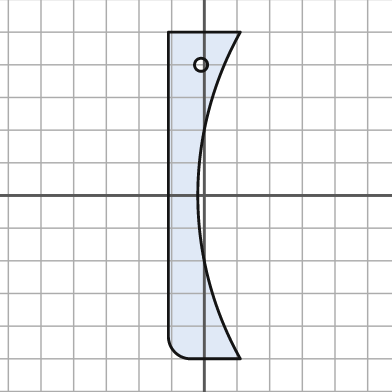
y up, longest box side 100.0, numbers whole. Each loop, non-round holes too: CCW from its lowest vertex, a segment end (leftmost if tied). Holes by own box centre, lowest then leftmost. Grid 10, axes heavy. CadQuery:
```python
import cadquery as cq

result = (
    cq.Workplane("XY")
    .moveTo(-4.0, -50.0)
    .lineTo(11.0, -50.0)
    .threePointArc((-2.0, 0.0), (11.0, 50.0))
    .lineTo(-11.0, 50.0)
    .lineTo(-11.0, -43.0)
    .threePointArc((-9.0, -48.0), (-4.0, -50.0))
    .close()
    .moveTo(-1.0, 40.0)
    .circle(2.0)
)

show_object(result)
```